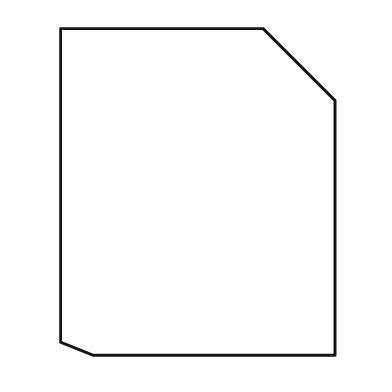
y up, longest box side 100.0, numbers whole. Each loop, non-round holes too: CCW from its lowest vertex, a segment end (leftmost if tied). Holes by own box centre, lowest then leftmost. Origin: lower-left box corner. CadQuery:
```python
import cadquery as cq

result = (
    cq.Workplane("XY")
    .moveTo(10.0, 0.0)
    .lineTo(84.0, 0.0)
    .lineTo(84.0, 78.0)
    .lineTo(62.0, 100.0)
    .lineTo(0.0, 100.0)
    .lineTo(0.0, 4.0)
    .close()
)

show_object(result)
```